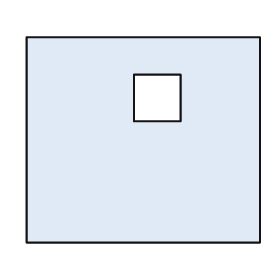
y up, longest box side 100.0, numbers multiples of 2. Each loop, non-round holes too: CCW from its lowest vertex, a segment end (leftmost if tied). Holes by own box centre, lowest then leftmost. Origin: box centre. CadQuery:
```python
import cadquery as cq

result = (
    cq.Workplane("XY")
    .moveTo(-50.0, -44.0)
    .lineTo(50.0, -44.0)
    .lineTo(50.0, 44.0)
    .lineTo(-50.0, 44.0)
    .close()
    .moveTo(-4.0, 8.0)
    .lineTo(16.0, 8.0)
    .lineTo(16.0, 28.0)
    .lineTo(-4.0, 28.0)
    .close()
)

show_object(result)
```